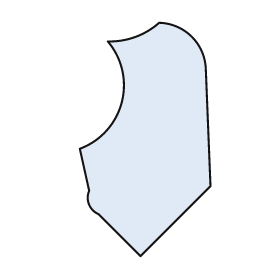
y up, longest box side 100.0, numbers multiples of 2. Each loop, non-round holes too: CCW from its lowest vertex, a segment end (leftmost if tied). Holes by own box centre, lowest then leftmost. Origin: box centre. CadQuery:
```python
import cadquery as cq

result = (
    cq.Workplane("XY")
    .moveTo(-2.0, -50.0)
    .lineTo(28.0, -20.0)
    .lineTo(26.0, 30.0)
    .threePointArc((20.0, 44.0), (6.0, 50.0))
    .threePointArc((-4.0, 44.0), (-16.0, 42.0))
    .threePointArc((-10.0, 16.0), (-28.0, -4.0))
    .lineTo(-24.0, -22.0)
    .threePointArc((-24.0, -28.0), (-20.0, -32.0))
    .close()
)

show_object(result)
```